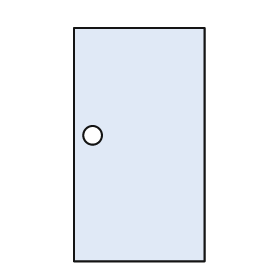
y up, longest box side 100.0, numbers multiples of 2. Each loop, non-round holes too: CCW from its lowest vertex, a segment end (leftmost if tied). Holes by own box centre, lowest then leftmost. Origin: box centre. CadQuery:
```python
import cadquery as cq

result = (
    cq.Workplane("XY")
    .moveTo(-28.0, -50.0)
    .lineTo(28.0, -50.0)
    .lineTo(28.0, 50.0)
    .lineTo(-28.0, 50.0)
    .close()
    .moveTo(-20.0, 4.0)
    .circle(4.0)
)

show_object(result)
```